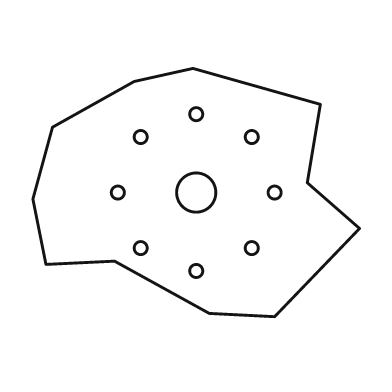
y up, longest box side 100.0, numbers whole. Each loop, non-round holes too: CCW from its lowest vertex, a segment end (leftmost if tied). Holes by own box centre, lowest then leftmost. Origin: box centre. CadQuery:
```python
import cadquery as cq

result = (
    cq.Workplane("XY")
    .moveTo(24.0, -38.0)
    .lineTo(50.0, -11.0)
    .lineTo(34.0, 3.0)
    .lineTo(38.0, 27.0)
    .lineTo(-1.0, 38.0)
    .lineTo(-19.0, 34.0)
    .lineTo(-44.0, 20.0)
    .lineTo(-50.0, -2.0)
    .lineTo(-46.0, -22.0)
    .lineTo(-25.0, -21.0)
    .lineTo(4.0, -37.0)
    .close()
    .moveTo(0.0, -24.0)
    .circle(2.0)
    .moveTo(-17.0, -17.0)
    .circle(2.0)
    .moveTo(17.0, -17.0)
    .circle(2.0)
    .moveTo(-24.0, 0.0)
    .circle(2.0)
    .moveTo(0.0, 0.0)
    .circle(6.0)
    .moveTo(24.0, 0.0)
    .circle(2.0)
    .moveTo(-17.0, 17.0)
    .circle(2.0)
    .moveTo(17.0, 17.0)
    .circle(2.0)
    .moveTo(0.0, 24.0)
    .circle(2.0)
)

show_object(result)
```